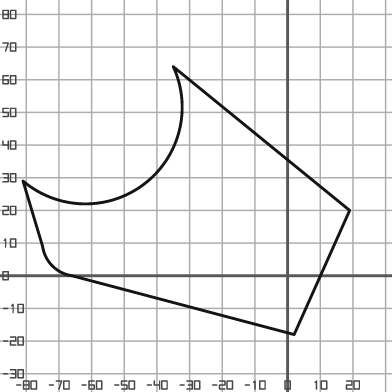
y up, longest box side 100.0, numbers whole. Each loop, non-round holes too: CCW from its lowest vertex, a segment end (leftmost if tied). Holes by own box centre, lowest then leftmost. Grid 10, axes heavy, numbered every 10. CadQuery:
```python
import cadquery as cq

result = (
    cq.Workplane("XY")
    .moveTo(2.0, -18.0)
    .lineTo(19.0, 20.0)
    .lineTo(-35.0, 64.0)
    .threePointArc((-44.0, 28.0), (-81.0, 29.0))
    .lineTo(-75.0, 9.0)
    .threePointArc((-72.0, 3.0), (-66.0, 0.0))
    .close()
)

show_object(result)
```